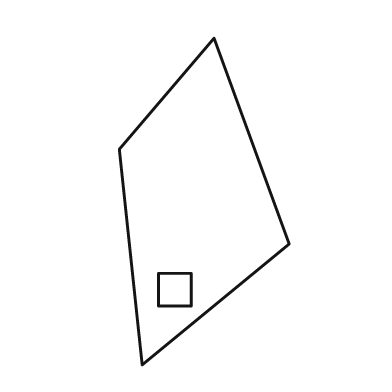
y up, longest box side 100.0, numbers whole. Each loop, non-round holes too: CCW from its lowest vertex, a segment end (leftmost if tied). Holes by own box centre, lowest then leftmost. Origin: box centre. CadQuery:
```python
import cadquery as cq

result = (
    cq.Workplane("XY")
    .moveTo(-19.0, -50.0)
    .lineTo(26.0, -13.0)
    .lineTo(3.0, 50.0)
    .lineTo(-26.0, 16.0)
    .close()
    .moveTo(-14.0, -32.0)
    .lineTo(-4.0, -32.0)
    .lineTo(-4.0, -22.0)
    .lineTo(-14.0, -22.0)
    .close()
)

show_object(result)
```